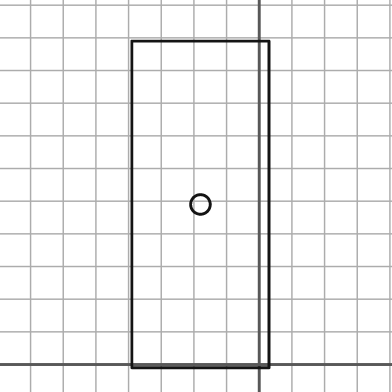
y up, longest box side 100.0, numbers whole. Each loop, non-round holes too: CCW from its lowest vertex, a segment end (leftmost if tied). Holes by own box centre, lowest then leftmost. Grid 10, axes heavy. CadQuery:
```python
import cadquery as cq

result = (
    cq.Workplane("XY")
    .moveTo(-39.0, -1.0)
    .lineTo(3.0, -1.0)
    .lineTo(3.0, 99.0)
    .lineTo(-39.0, 99.0)
    .close()
    .moveTo(-18.0, 49.0)
    .circle(3.0)
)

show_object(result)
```